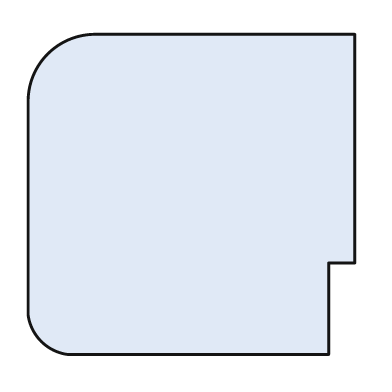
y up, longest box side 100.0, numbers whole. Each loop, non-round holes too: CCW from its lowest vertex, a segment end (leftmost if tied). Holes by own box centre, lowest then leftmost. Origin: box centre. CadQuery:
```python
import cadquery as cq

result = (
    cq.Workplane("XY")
    .moveTo(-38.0, -49.0)
    .lineTo(42.0, -49.0)
    .lineTo(42.0, -21.0)
    .lineTo(50.0, -21.0)
    .lineTo(50.0, 49.0)
    .lineTo(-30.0, 49.0)
    .threePointArc((-44.0, 43.0), (-50.0, 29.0))
    .lineTo(-50.0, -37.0)
    .threePointArc((-46.0, -45.0), (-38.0, -49.0))
    .close()
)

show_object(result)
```